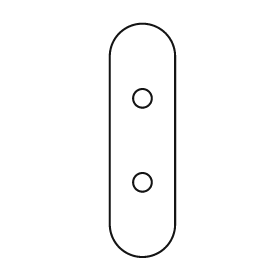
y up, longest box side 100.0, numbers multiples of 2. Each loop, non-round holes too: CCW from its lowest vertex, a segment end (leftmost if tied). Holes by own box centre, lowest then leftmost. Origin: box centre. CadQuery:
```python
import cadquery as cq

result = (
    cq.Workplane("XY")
    .moveTo(-14.0, -36.0)
    .threePointArc((0.0, -50.0), (14.0, -36.0))
    .lineTo(14.0, 36.0)
    .threePointArc((0.0, 50.0), (-14.0, 36.0))
    .close()
    .moveTo(0.0, -18.0)
    .circle(4.0)
    .moveTo(0.0, 18.0)
    .circle(4.0)
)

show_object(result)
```